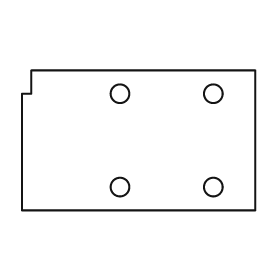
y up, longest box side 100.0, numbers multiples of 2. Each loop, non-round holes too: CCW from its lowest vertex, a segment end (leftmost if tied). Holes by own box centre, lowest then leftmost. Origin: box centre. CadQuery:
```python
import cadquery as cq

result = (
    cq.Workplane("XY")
    .moveTo(-50.0, -30.0)
    .lineTo(50.0, -30.0)
    .lineTo(50.0, 30.0)
    .lineTo(-46.0, 30.0)
    .lineTo(-46.0, 20.0)
    .lineTo(-50.0, 20.0)
    .close()
    .moveTo(-8.0, -20.0)
    .circle(4.0)
    .moveTo(32.0, -20.0)
    .circle(4.0)
    .moveTo(-8.0, 20.0)
    .circle(4.0)
    .moveTo(32.0, 20.0)
    .circle(4.0)
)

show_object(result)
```